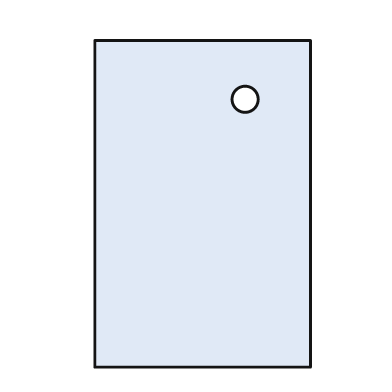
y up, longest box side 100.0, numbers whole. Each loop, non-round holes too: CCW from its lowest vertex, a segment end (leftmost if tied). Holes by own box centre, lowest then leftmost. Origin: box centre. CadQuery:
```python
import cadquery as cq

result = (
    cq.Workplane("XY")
    .moveTo(-33.0, -50.0)
    .lineTo(33.0, -50.0)
    .lineTo(33.0, 50.0)
    .lineTo(-33.0, 50.0)
    .close()
    .moveTo(13.0, 32.0)
    .circle(4.0)
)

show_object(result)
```